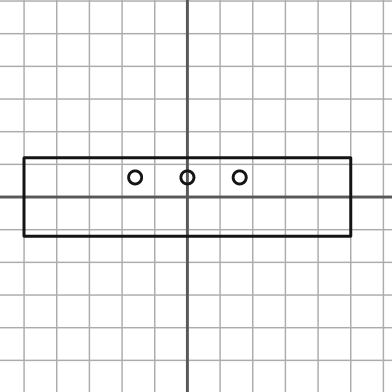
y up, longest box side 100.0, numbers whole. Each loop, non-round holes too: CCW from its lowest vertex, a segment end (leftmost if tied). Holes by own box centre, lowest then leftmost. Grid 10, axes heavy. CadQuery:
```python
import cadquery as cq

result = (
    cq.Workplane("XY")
    .moveTo(-50.0, -12.0)
    .lineTo(50.0, -12.0)
    .lineTo(50.0, 12.0)
    .lineTo(-50.0, 12.0)
    .close()
    .moveTo(-16.0, 6.0)
    .circle(2.0)
    .moveTo(0.0, 6.0)
    .circle(2.0)
    .moveTo(16.0, 6.0)
    .circle(2.0)
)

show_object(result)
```